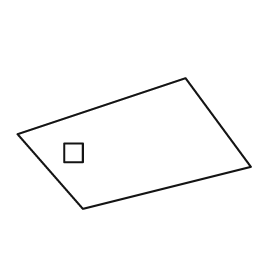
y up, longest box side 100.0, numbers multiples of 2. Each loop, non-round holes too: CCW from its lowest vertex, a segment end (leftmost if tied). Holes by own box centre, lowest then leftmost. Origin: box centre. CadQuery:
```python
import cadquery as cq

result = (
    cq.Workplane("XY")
    .moveTo(-22.0, -28.0)
    .lineTo(50.0, -10.0)
    .lineTo(22.0, 28.0)
    .lineTo(-50.0, 4.0)
    .close()
    .moveTo(-30.0, -8.0)
    .lineTo(-22.0, -8.0)
    .lineTo(-22.0, 0.0)
    .lineTo(-30.0, 0.0)
    .close()
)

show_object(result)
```